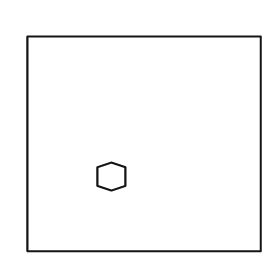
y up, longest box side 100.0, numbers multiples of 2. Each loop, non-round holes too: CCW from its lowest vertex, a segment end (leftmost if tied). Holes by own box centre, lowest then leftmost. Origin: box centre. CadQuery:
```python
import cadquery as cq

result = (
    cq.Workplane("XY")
    .moveTo(-50.0, -46.0)
    .lineTo(50.0, -46.0)
    .lineTo(50.0, 46.0)
    .lineTo(-50.0, 46.0)
    .close()
    .moveTo(-14.0, -20.0)
    .lineTo(-8.0, -18.0)
    .lineTo(-8.0, -10.0)
    .lineTo(-14.0, -8.0)
    .lineTo(-20.0, -10.0)
    .lineTo(-20.0, -18.0)
    .close()
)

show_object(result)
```